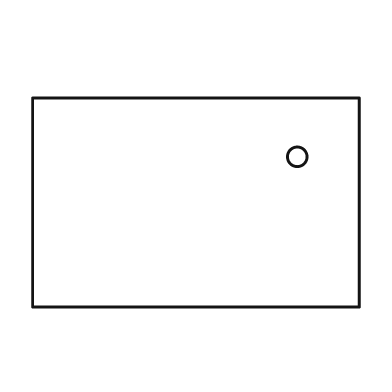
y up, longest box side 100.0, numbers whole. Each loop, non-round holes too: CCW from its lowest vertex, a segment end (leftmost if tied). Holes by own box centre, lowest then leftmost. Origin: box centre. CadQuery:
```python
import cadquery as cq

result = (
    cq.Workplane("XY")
    .moveTo(-50.0, -32.0)
    .lineTo(50.0, -32.0)
    .lineTo(50.0, 32.0)
    .lineTo(-50.0, 32.0)
    .close()
    .moveTo(31.0, 14.0)
    .circle(3.0)
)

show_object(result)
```